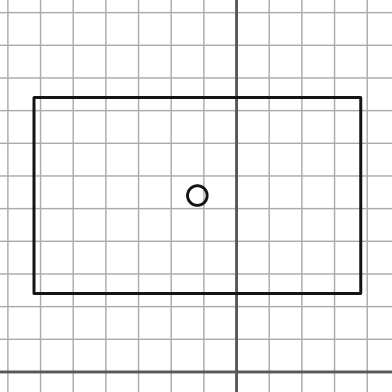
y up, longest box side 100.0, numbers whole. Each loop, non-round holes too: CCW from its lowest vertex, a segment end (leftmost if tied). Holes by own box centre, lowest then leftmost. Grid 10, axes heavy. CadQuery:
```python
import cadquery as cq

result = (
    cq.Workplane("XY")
    .moveTo(-62.0, 24.0)
    .lineTo(38.0, 24.0)
    .lineTo(38.0, 84.0)
    .lineTo(-62.0, 84.0)
    .close()
    .moveTo(-12.0, 54.0)
    .circle(3.0)
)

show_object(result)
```